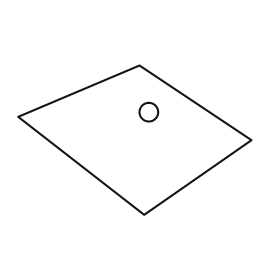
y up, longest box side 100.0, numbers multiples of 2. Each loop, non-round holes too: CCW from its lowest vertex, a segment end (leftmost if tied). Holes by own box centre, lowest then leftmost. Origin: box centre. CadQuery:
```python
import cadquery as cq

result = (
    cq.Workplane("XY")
    .moveTo(4.0, -32.0)
    .lineTo(50.0, 0.0)
    .lineTo(2.0, 32.0)
    .lineTo(-50.0, 10.0)
    .close()
    .moveTo(6.0, 12.0)
    .circle(4.0)
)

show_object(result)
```